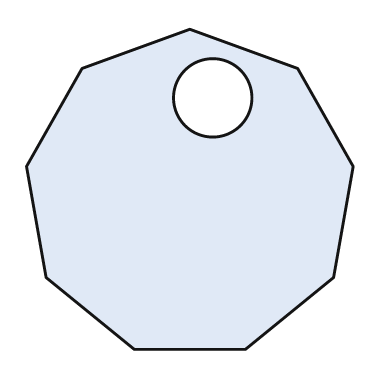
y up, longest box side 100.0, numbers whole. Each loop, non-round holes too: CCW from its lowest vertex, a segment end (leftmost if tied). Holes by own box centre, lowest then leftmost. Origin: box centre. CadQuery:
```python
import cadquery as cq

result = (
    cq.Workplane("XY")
    .moveTo(-17.0, -49.0)
    .lineTo(17.0, -49.0)
    .lineTo(44.0, -27.0)
    .lineTo(50.0, 7.0)
    .lineTo(33.0, 37.0)
    .lineTo(0.0, 49.0)
    .lineTo(-33.0, 37.0)
    .lineTo(-50.0, 7.0)
    .lineTo(-44.0, -27.0)
    .close()
    .moveTo(7.0, 28.0)
    .circle(12.0)
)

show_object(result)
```